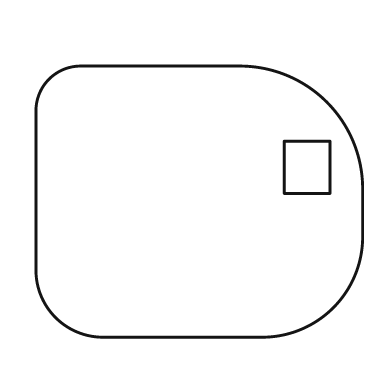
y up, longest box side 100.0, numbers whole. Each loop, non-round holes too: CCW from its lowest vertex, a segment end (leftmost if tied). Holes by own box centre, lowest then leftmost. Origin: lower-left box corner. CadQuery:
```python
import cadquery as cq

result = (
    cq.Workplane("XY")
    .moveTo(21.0, 0.0)
    .lineTo(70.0, 0.0)
    .threePointArc((91.0, 9.0), (100.0, 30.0))
    .lineTo(100.0, 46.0)
    .threePointArc((89.0, 72.0), (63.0, 83.0))
    .lineTo(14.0, 83.0)
    .threePointArc((4.0, 79.0), (0.0, 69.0))
    .lineTo(0.0, 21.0)
    .threePointArc((6.0, 6.0), (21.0, 0.0))
    .close()
    .moveTo(76.0, 44.0)
    .lineTo(90.0, 44.0)
    .lineTo(90.0, 60.0)
    .lineTo(76.0, 60.0)
    .close()
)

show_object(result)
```